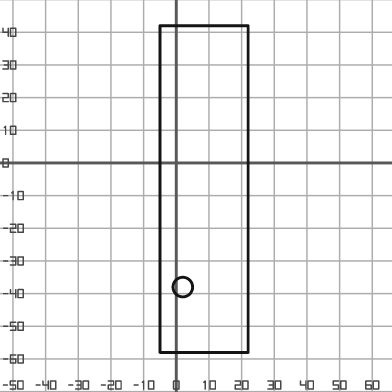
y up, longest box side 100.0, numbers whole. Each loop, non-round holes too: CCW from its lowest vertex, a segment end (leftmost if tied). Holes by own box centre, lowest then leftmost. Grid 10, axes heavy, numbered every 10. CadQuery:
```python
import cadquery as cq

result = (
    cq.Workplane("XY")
    .moveTo(-5.0, -58.0)
    .lineTo(22.0, -58.0)
    .lineTo(22.0, 42.0)
    .lineTo(-5.0, 42.0)
    .close()
    .moveTo(2.0, -38.0)
    .circle(3.0)
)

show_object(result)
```